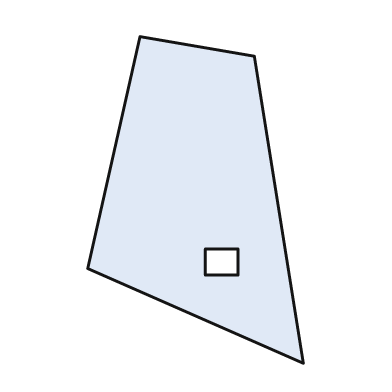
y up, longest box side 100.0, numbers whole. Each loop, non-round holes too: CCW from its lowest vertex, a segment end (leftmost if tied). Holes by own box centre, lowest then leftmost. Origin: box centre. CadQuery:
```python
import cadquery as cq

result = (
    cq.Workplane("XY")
    .moveTo(33.0, -50.0)
    .lineTo(18.0, 44.0)
    .lineTo(-17.0, 50.0)
    .lineTo(-33.0, -21.0)
    .close()
    .moveTo(3.0, -23.0)
    .lineTo(13.0, -23.0)
    .lineTo(13.0, -15.0)
    .lineTo(3.0, -15.0)
    .close()
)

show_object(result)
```